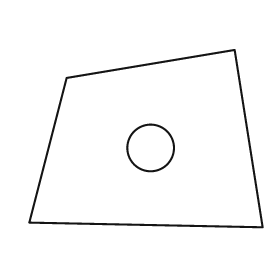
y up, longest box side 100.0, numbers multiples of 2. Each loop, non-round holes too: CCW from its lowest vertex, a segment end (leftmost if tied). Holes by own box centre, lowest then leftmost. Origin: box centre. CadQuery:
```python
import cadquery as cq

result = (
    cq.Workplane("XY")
    .moveTo(50.0, -38.0)
    .lineTo(38.0, 38.0)
    .lineTo(-34.0, 26.0)
    .lineTo(-50.0, -36.0)
    .close()
    .moveTo(2.0, -4.0)
    .circle(10.0)
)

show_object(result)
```